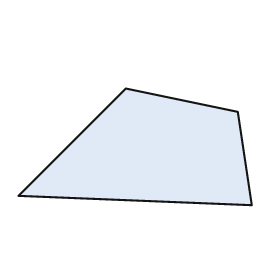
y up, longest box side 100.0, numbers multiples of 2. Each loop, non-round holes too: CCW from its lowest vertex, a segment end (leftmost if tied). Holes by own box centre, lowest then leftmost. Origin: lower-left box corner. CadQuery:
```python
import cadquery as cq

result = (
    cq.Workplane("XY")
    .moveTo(100.0, 0.0)
    .lineTo(94.0, 40.0)
    .lineTo(46.0, 50.0)
    .lineTo(0.0, 4.0)
    .close()
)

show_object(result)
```